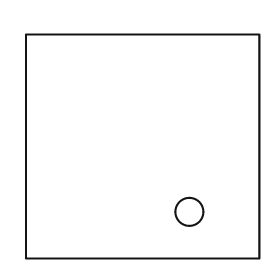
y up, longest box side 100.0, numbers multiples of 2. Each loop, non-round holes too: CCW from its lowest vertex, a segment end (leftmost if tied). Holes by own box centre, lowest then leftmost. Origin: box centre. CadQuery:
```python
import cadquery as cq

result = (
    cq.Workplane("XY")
    .moveTo(-50.0, -48.0)
    .lineTo(50.0, -48.0)
    .lineTo(50.0, 48.0)
    .lineTo(-50.0, 48.0)
    .close()
    .moveTo(20.0, -28.0)
    .circle(6.0)
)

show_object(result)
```